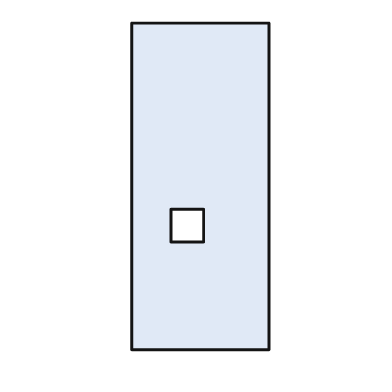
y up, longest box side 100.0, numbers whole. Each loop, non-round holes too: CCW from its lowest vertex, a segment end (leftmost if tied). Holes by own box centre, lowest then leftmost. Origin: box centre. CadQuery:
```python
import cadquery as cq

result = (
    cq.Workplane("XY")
    .moveTo(-21.0, -50.0)
    .lineTo(21.0, -50.0)
    .lineTo(21.0, 50.0)
    .lineTo(-21.0, 50.0)
    .close()
    .moveTo(-9.0, -17.0)
    .lineTo(1.0, -17.0)
    .lineTo(1.0, -7.0)
    .lineTo(-9.0, -7.0)
    .close()
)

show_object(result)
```